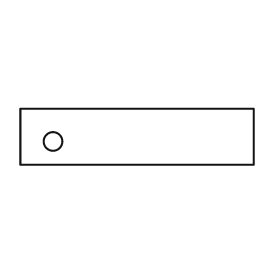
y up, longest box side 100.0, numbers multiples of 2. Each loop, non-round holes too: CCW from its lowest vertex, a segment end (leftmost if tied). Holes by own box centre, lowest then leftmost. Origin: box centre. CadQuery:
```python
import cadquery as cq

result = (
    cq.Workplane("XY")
    .moveTo(-50.0, -12.0)
    .lineTo(50.0, -12.0)
    .lineTo(50.0, 12.0)
    .lineTo(-50.0, 12.0)
    .close()
    .moveTo(-36.0, -2.0)
    .circle(4.0)
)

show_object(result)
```